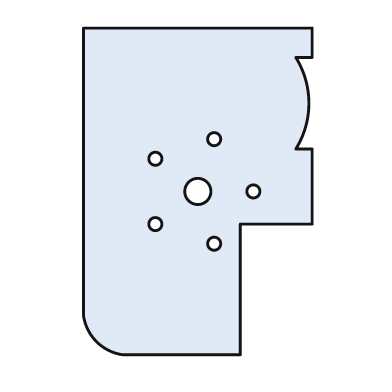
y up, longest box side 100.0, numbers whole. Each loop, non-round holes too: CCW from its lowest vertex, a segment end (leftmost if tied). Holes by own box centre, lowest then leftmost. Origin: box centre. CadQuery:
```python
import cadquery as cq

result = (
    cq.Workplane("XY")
    .moveTo(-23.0, -50.0)
    .lineTo(13.0, -50.0)
    .lineTo(13.0, -10.0)
    .lineTo(35.0, -10.0)
    .lineTo(35.0, 13.0)
    .lineTo(30.0, 13.0)
    .threePointArc((34.0, 27.0), (30.0, 41.0))
    .lineTo(35.0, 41.0)
    .lineTo(35.0, 50.0)
    .lineTo(-35.0, 50.0)
    .lineTo(-35.0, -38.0)
    .threePointArc((-31.0, -46.0), (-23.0, -50.0))
    .close()
    .moveTo(5.0, -16.0)
    .circle(2.0)
    .moveTo(-13.0, -10.0)
    .circle(2.0)
    .moveTo(0.0, 0.0)
    .circle(4.0)
    .moveTo(17.0, 0.0)
    .circle(2.0)
    .moveTo(-13.0, 10.0)
    .circle(2.0)
    .moveTo(5.0, 16.0)
    .circle(2.0)
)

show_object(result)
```